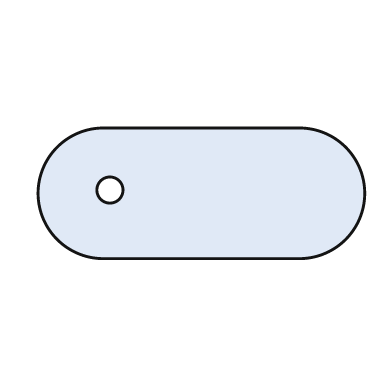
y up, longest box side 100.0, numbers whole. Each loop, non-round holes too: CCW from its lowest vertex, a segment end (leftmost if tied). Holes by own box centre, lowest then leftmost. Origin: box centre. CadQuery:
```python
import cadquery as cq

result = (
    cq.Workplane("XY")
    .moveTo(-30.0, -20.0)
    .lineTo(30.0, -20.0)
    .threePointArc((50.0, 0.0), (30.0, 20.0))
    .lineTo(-30.0, 20.0)
    .threePointArc((-50.0, 0.0), (-30.0, -20.0))
    .close()
    .moveTo(-28.0, 1.0)
    .circle(4.0)
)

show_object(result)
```